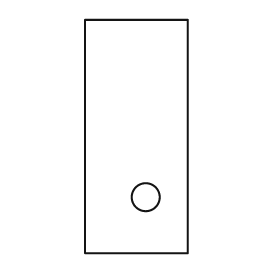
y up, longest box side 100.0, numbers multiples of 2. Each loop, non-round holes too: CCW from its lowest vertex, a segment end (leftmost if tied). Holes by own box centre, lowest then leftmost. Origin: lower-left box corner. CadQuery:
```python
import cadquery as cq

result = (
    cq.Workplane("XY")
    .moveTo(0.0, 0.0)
    .lineTo(44.0, 0.0)
    .lineTo(44.0, 100.0)
    .lineTo(0.0, 100.0)
    .close()
    .moveTo(26.0, 24.0)
    .circle(6.0)
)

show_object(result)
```